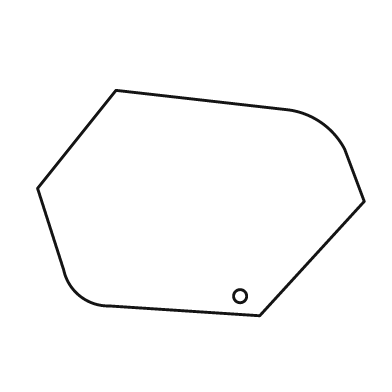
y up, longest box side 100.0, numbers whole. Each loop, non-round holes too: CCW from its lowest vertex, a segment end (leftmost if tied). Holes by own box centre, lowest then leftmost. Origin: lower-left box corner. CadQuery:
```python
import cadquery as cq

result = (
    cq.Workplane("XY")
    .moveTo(68.0, 0.0)
    .lineTo(100.0, 35.0)
    .lineTo(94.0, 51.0)
    .threePointArc((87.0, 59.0), (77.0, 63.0))
    .lineTo(24.0, 69.0)
    .lineTo(0.0, 39.0)
    .lineTo(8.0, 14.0)
    .threePointArc((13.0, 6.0), (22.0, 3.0))
    .close()
    .moveTo(62.0, 6.0)
    .circle(2.0)
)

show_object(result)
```